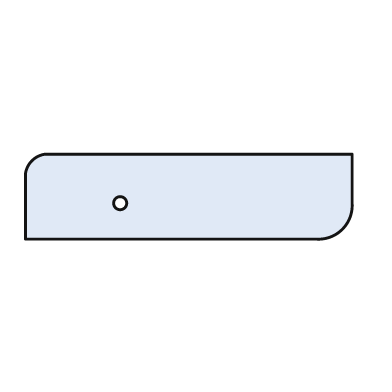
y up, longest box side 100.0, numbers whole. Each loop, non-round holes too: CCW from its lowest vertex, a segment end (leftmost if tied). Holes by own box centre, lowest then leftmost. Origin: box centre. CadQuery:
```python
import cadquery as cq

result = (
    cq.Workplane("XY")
    .moveTo(-50.0, -13.0)
    .lineTo(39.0, -13.0)
    .threePointArc((47.0, -10.0), (50.0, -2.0))
    .lineTo(50.0, 13.0)
    .lineTo(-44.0, 13.0)
    .threePointArc((-48.0, 11.0), (-50.0, 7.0))
    .close()
    .moveTo(-21.0, -2.0)
    .circle(2.0)
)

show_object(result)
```